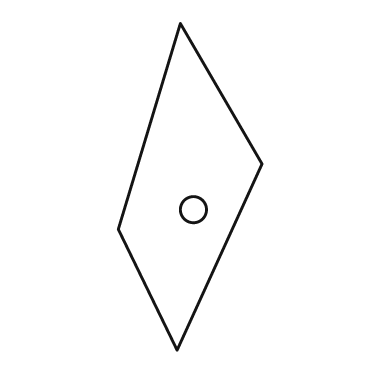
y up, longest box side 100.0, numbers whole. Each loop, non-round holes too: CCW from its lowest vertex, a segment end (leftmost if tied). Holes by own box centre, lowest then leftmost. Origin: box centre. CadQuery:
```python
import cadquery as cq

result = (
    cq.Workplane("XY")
    .moveTo(-4.0, -50.0)
    .lineTo(22.0, 7.0)
    .lineTo(-3.0, 50.0)
    .lineTo(-22.0, -13.0)
    .close()
    .moveTo(1.0, -7.0)
    .circle(4.0)
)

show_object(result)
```